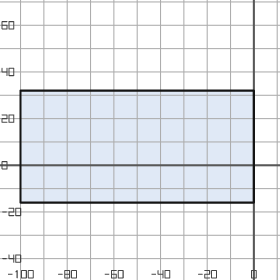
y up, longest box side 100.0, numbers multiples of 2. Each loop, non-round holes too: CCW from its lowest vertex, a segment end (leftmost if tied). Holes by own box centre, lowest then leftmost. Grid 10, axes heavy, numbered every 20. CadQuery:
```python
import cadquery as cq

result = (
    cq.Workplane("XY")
    .moveTo(-100.0, -16.0)
    .lineTo(0.0, -16.0)
    .lineTo(0.0, 32.0)
    .lineTo(-100.0, 32.0)
    .close()
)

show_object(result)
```